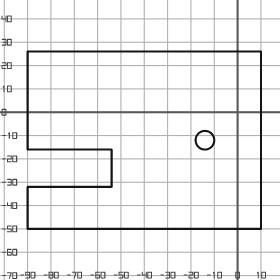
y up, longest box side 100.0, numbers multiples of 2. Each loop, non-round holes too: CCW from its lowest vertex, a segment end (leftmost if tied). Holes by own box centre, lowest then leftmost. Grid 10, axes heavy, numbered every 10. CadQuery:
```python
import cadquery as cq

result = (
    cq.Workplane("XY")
    .moveTo(-90.0, -50.0)
    .lineTo(10.0, -50.0)
    .lineTo(10.0, 26.0)
    .lineTo(-90.0, 26.0)
    .lineTo(-90.0, -16.0)
    .lineTo(-54.0, -16.0)
    .lineTo(-54.0, -32.0)
    .lineTo(-90.0, -32.0)
    .close()
    .moveTo(-14.0, -12.0)
    .circle(4.0)
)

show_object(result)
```